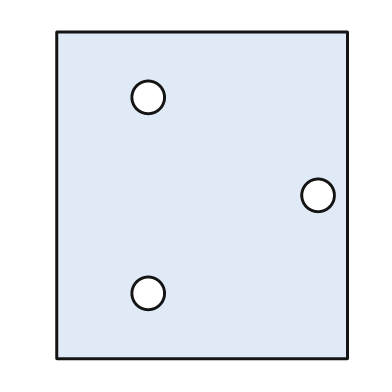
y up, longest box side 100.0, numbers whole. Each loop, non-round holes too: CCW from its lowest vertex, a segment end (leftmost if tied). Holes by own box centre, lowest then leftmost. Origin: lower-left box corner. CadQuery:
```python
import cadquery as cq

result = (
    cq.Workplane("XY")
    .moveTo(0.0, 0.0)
    .lineTo(89.0, 0.0)
    .lineTo(89.0, 100.0)
    .lineTo(0.0, 100.0)
    .close()
    .moveTo(28.0, 20.0)
    .circle(5.0)
    .moveTo(80.0, 50.0)
    .circle(5.0)
    .moveTo(28.0, 80.0)
    .circle(5.0)
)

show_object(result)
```